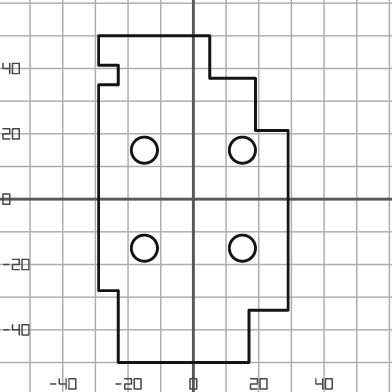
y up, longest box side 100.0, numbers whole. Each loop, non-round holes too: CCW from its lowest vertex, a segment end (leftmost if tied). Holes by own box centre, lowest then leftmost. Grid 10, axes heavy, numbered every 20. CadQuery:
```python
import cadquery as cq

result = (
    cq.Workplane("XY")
    .moveTo(-23.0, -50.0)
    .lineTo(17.0, -50.0)
    .lineTo(17.0, -34.0)
    .lineTo(29.0, -34.0)
    .lineTo(29.0, 21.0)
    .lineTo(19.0, 21.0)
    .lineTo(19.0, 37.0)
    .lineTo(5.0, 37.0)
    .lineTo(5.0, 50.0)
    .lineTo(-29.0, 50.0)
    .lineTo(-29.0, 41.0)
    .lineTo(-23.0, 41.0)
    .lineTo(-23.0, 35.0)
    .lineTo(-29.0, 35.0)
    .lineTo(-29.0, -28.0)
    .lineTo(-23.0, -28.0)
    .close()
    .moveTo(-15.0, -15.0)
    .circle(4.0)
    .moveTo(15.0, -15.0)
    .circle(4.0)
    .moveTo(-15.0, 15.0)
    .circle(4.0)
    .moveTo(15.0, 15.0)
    .circle(4.0)
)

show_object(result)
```